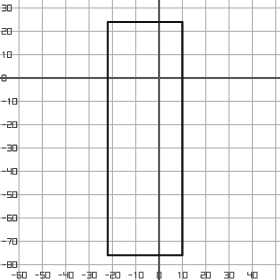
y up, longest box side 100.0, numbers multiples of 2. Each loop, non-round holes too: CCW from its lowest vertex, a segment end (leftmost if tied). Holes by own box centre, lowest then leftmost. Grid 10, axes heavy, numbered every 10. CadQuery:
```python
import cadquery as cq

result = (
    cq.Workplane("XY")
    .moveTo(-22.0, -76.0)
    .lineTo(10.0, -76.0)
    .lineTo(10.0, 24.0)
    .lineTo(-22.0, 24.0)
    .close()
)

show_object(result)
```